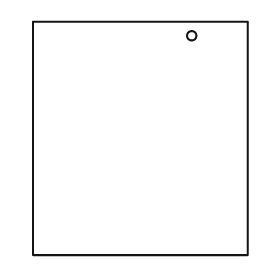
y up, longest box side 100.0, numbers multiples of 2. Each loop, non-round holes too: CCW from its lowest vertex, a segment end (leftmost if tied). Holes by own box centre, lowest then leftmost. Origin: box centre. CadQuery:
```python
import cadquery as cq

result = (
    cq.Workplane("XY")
    .moveTo(-46.0, -50.0)
    .lineTo(46.0, -50.0)
    .lineTo(46.0, 50.0)
    .lineTo(-46.0, 50.0)
    .close()
    .moveTo(22.0, 44.0)
    .circle(2.0)
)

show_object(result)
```